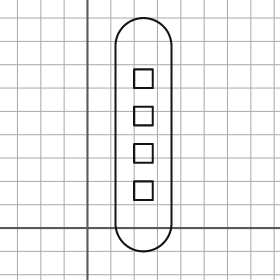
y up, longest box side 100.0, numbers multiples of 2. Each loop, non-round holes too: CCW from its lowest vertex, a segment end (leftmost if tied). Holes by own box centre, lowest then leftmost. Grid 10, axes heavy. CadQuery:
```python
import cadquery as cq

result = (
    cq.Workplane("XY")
    .moveTo(12.0, 2.0)
    .threePointArc((24.0, -10.0), (36.0, 2.0))
    .lineTo(36.0, 78.0)
    .threePointArc((24.0, 90.0), (12.0, 78.0))
    .close()
    .moveTo(20.0, 12.0)
    .lineTo(28.0, 12.0)
    .lineTo(28.0, 20.0)
    .lineTo(20.0, 20.0)
    .close()
    .moveTo(20.0, 28.0)
    .lineTo(28.0, 28.0)
    .lineTo(28.0, 36.0)
    .lineTo(20.0, 36.0)
    .close()
    .moveTo(20.0, 44.0)
    .lineTo(28.0, 44.0)
    .lineTo(28.0, 52.0)
    .lineTo(20.0, 52.0)
    .close()
    .moveTo(20.0, 60.0)
    .lineTo(28.0, 60.0)
    .lineTo(28.0, 68.0)
    .lineTo(20.0, 68.0)
    .close()
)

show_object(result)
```